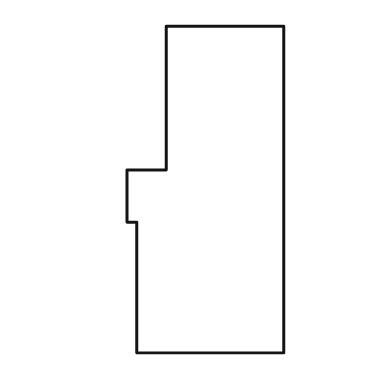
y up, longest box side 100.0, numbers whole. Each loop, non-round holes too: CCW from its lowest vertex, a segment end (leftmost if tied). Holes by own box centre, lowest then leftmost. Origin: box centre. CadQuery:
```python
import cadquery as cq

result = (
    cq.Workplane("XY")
    .moveTo(-21.0, -50.0)
    .lineTo(24.0, -50.0)
    .lineTo(24.0, 50.0)
    .lineTo(-12.0, 50.0)
    .lineTo(-12.0, 6.0)
    .lineTo(-24.0, 6.0)
    .lineTo(-24.0, -10.0)
    .lineTo(-21.0, -10.0)
    .close()
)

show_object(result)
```